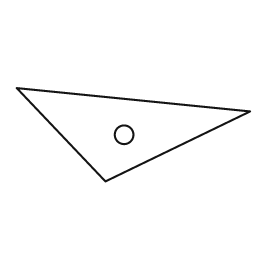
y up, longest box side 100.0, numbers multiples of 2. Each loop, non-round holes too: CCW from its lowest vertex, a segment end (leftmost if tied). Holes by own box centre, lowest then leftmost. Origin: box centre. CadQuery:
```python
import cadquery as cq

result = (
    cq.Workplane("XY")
    .moveTo(-12.0, -20.0)
    .lineTo(50.0, 10.0)
    .lineTo(-50.0, 20.0)
    .close()
    .moveTo(-4.0, 0.0)
    .circle(4.0)
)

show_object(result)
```